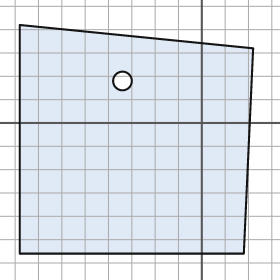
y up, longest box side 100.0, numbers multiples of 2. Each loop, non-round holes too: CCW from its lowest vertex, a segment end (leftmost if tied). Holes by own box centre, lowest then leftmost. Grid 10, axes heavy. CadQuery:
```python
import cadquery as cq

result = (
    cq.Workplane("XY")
    .moveTo(-78.0, -56.0)
    .lineTo(18.0, -56.0)
    .lineTo(22.0, 32.0)
    .lineTo(-78.0, 42.0)
    .close()
    .moveTo(-34.0, 18.0)
    .circle(4.0)
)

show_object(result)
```